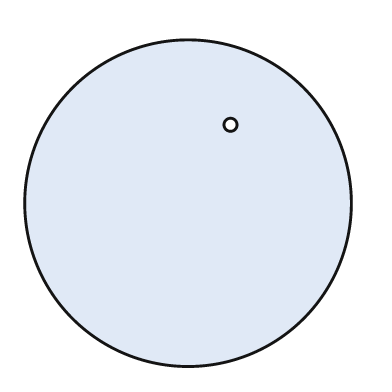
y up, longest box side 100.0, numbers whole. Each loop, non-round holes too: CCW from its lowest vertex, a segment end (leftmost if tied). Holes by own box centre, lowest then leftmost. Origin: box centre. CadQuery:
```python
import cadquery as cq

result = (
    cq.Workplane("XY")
    .moveTo(0.0, 0.0)
    .circle(50.0)
    .moveTo(13.0, 24.0)
    .circle(2.0)
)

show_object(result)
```